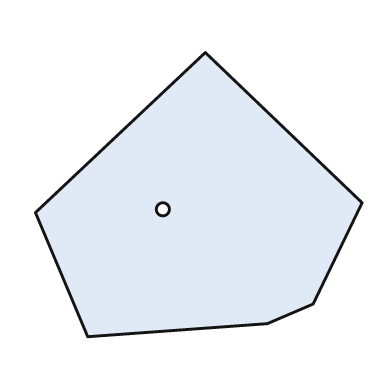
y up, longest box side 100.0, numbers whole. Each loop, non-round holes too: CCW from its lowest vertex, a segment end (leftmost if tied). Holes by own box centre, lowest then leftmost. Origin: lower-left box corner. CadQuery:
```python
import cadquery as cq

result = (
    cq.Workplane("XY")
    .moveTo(16.0, 0.0)
    .lineTo(71.0, 4.0)
    .lineTo(85.0, 10.0)
    .lineTo(100.0, 41.0)
    .lineTo(52.0, 87.0)
    .lineTo(0.0, 38.0)
    .close()
    .moveTo(39.0, 39.0)
    .circle(2.0)
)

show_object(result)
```